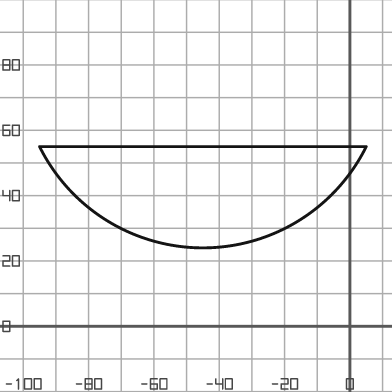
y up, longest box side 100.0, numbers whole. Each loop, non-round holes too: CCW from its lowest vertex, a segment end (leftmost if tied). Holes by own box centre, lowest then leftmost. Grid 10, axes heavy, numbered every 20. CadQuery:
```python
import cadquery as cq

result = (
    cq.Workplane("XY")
    .moveTo(-95.0, 55.0)
    .threePointArc((-45.0, 24.0), (5.0, 55.0))
    .close()
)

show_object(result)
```